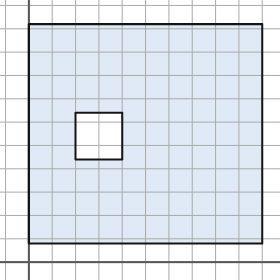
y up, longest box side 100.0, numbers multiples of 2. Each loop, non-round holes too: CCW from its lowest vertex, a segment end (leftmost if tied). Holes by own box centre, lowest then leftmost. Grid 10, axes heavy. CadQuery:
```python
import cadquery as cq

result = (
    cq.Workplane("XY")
    .moveTo(0.0, 8.0)
    .lineTo(100.0, 8.0)
    .lineTo(100.0, 102.0)
    .lineTo(0.0, 102.0)
    .close()
    .moveTo(20.0, 44.0)
    .lineTo(40.0, 44.0)
    .lineTo(40.0, 64.0)
    .lineTo(20.0, 64.0)
    .close()
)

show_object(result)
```